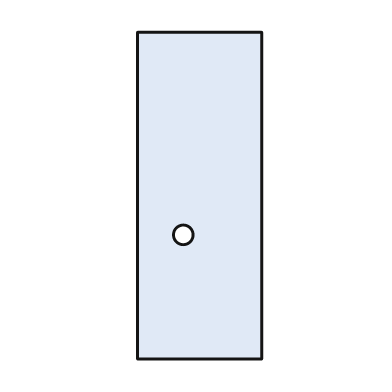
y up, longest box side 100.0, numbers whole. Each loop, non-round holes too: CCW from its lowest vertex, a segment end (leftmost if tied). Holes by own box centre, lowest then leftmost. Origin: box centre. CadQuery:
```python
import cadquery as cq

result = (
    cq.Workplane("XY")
    .moveTo(-19.0, -50.0)
    .lineTo(19.0, -50.0)
    .lineTo(19.0, 50.0)
    .lineTo(-19.0, 50.0)
    .close()
    .moveTo(-5.0, -12.0)
    .circle(3.0)
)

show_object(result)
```